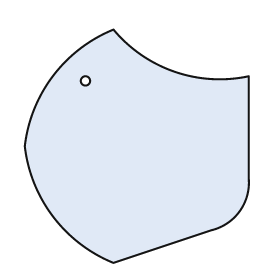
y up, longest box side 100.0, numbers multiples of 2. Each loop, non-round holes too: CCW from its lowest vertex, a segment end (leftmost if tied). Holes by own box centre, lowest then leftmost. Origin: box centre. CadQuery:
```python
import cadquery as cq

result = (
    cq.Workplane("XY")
    .moveTo(-10.0, -50.0)
    .lineTo(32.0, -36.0)
    .threePointArc((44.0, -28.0), (48.0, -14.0))
    .lineTo(48.0, 30.0)
    .threePointArc((16.0, 32.0), (-10.0, 50.0))
    .threePointArc((-36.0, 30.0), (-48.0, 0.0))
    .threePointArc((-36.0, -30.0), (-10.0, -50.0))
    .close()
    .moveTo(-22.0, 28.0)
    .circle(2.0)
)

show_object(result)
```